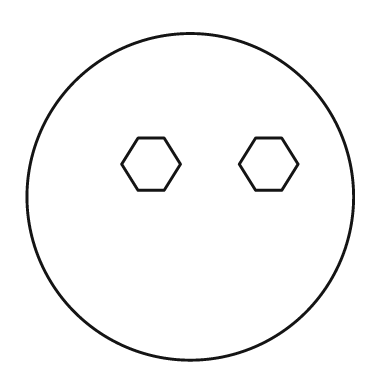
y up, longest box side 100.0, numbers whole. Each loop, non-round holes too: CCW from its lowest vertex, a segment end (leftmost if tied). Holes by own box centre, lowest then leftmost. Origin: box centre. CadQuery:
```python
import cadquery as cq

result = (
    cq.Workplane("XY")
    .moveTo(0.0, 0.0)
    .circle(50.0)
    .moveTo(-16.0, 2.0)
    .lineTo(-8.0, 2.0)
    .lineTo(-3.0, 10.0)
    .lineTo(-8.0, 18.0)
    .lineTo(-16.0, 18.0)
    .lineTo(-21.0, 10.0)
    .close()
    .moveTo(20.0, 2.0)
    .lineTo(28.0, 2.0)
    .lineTo(33.0, 10.0)
    .lineTo(28.0, 18.0)
    .lineTo(20.0, 18.0)
    .lineTo(15.0, 10.0)
    .close()
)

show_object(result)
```